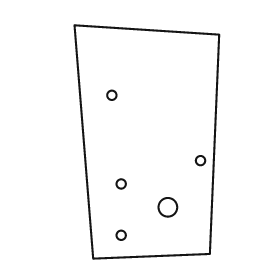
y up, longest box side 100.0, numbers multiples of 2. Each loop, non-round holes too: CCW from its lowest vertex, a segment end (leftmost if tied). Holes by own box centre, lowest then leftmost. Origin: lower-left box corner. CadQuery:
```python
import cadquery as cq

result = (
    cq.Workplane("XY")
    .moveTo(8.0, 0.0)
    .lineTo(58.0, 2.0)
    .lineTo(62.0, 96.0)
    .lineTo(0.0, 100.0)
    .close()
    .moveTo(20.0, 10.0)
    .circle(2.0)
    .moveTo(40.0, 22.0)
    .circle(4.0)
    .moveTo(20.0, 32.0)
    .circle(2.0)
    .moveTo(54.0, 42.0)
    .circle(2.0)
    .moveTo(16.0, 70.0)
    .circle(2.0)
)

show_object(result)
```